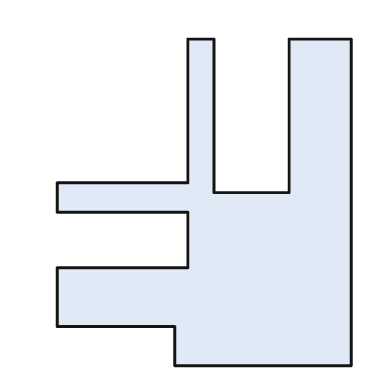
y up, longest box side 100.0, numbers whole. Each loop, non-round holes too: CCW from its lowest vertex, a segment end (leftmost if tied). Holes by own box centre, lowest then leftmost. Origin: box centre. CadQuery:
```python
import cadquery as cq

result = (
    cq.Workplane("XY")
    .moveTo(-9.0, -50.0)
    .lineTo(45.0, -50.0)
    .lineTo(45.0, 50.0)
    .lineTo(26.0, 50.0)
    .lineTo(26.0, 3.0)
    .lineTo(3.0, 3.0)
    .lineTo(3.0, 50.0)
    .lineTo(-5.0, 50.0)
    .lineTo(-5.0, 6.0)
    .lineTo(-45.0, 6.0)
    .lineTo(-45.0, -3.0)
    .lineTo(-5.0, -3.0)
    .lineTo(-5.0, -20.0)
    .lineTo(-45.0, -20.0)
    .lineTo(-45.0, -38.0)
    .lineTo(-9.0, -38.0)
    .close()
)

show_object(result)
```